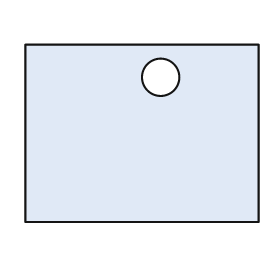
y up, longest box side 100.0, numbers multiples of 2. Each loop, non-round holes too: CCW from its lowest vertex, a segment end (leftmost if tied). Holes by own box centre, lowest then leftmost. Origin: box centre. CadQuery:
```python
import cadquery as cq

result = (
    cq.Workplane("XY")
    .moveTo(-50.0, -38.0)
    .lineTo(50.0, -38.0)
    .lineTo(50.0, 38.0)
    .lineTo(-50.0, 38.0)
    .close()
    .moveTo(8.0, 24.0)
    .circle(8.0)
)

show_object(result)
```